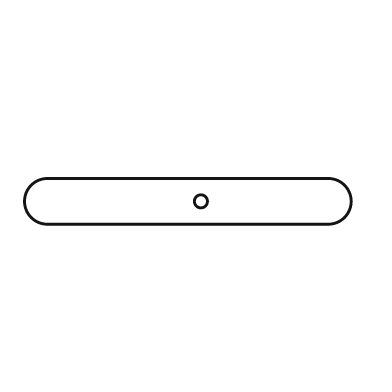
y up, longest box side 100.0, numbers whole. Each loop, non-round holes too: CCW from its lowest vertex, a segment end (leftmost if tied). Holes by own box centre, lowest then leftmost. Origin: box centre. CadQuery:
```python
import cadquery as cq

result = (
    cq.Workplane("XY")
    .moveTo(-43.0, -7.0)
    .lineTo(43.0, -7.0)
    .threePointArc((50.0, 0.0), (43.0, 7.0))
    .lineTo(-43.0, 7.0)
    .threePointArc((-50.0, 0.0), (-43.0, -7.0))
    .close()
    .moveTo(4.0, 0.0)
    .circle(2.0)
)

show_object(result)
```